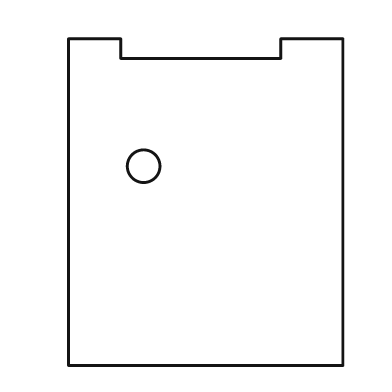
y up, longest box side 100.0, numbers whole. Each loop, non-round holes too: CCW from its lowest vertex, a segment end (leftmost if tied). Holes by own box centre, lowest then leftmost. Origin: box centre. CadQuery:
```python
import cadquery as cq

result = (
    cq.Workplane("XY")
    .moveTo(-42.0, -50.0)
    .lineTo(42.0, -50.0)
    .lineTo(42.0, 50.0)
    .lineTo(23.0, 50.0)
    .lineTo(23.0, 44.0)
    .lineTo(-26.0, 44.0)
    .lineTo(-26.0, 50.0)
    .lineTo(-42.0, 50.0)
    .close()
    .moveTo(-19.0, 11.0)
    .circle(5.0)
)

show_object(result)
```